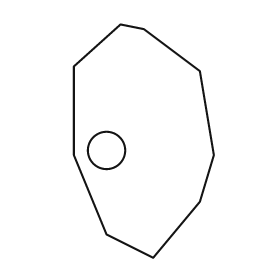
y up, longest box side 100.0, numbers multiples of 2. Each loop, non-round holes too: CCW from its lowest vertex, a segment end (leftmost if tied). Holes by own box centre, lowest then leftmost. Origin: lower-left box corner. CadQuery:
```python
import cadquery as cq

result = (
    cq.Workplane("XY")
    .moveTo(34.0, 0.0)
    .lineTo(54.0, 24.0)
    .lineTo(60.0, 44.0)
    .lineTo(54.0, 80.0)
    .lineTo(30.0, 98.0)
    .lineTo(20.0, 100.0)
    .lineTo(0.0, 82.0)
    .lineTo(0.0, 44.0)
    .lineTo(14.0, 10.0)
    .close()
    .moveTo(14.0, 46.0)
    .circle(8.0)
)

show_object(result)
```